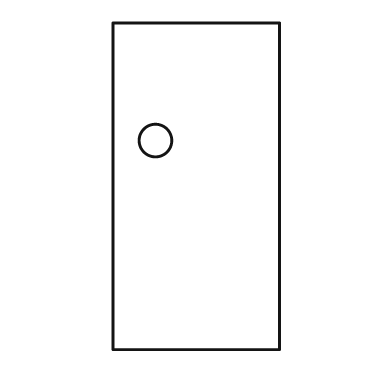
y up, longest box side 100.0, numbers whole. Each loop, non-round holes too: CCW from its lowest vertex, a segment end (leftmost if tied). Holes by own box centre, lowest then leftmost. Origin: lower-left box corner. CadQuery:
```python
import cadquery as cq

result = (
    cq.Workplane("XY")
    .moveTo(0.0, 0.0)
    .lineTo(51.0, 0.0)
    .lineTo(51.0, 100.0)
    .lineTo(0.0, 100.0)
    .close()
    .moveTo(13.0, 64.0)
    .circle(5.0)
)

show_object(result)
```